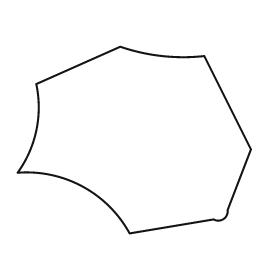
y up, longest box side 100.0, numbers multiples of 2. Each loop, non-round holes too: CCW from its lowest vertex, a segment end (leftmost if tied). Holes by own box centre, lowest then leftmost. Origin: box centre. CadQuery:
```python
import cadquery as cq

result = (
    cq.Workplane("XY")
    .moveTo(-2.0, -40.0)
    .lineTo(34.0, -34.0)
    .threePointArc((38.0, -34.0), (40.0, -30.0))
    .lineTo(50.0, -4.0)
    .lineTo(30.0, 36.0)
    .threePointArc((12.0, 36.0), (-6.0, 40.0))
    .lineTo(-42.0, 24.0)
    .threePointArc((-42.0, 4.0), (-50.0, -14.0))
    .threePointArc((-22.0, -20.0), (-2.0, -40.0))
    .close()
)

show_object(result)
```